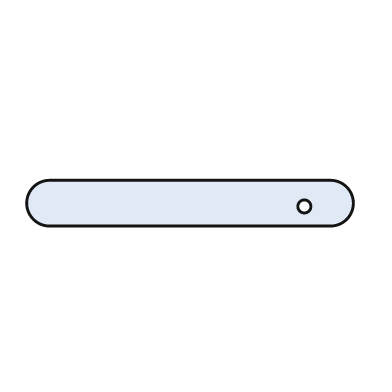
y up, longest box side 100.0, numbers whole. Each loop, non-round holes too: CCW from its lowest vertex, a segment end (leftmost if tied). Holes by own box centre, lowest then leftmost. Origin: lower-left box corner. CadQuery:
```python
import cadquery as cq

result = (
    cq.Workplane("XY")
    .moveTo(7.0, 0.0)
    .lineTo(93.0, 0.0)
    .threePointArc((100.0, 7.0), (93.0, 14.0))
    .lineTo(7.0, 14.0)
    .threePointArc((0.0, 7.0), (7.0, 0.0))
    .close()
    .moveTo(85.0, 6.0)
    .circle(2.0)
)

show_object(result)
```